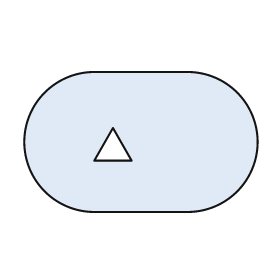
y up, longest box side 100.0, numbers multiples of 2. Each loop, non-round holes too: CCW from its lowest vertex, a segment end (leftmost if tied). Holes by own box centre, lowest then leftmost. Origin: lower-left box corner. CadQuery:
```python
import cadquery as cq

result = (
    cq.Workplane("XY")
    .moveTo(30.0, 0.0)
    .lineTo(70.0, 0.0)
    .threePointArc((100.0, 30.0), (70.0, 60.0))
    .lineTo(30.0, 60.0)
    .threePointArc((0.0, 30.0), (30.0, 0.0))
    .close()
    .moveTo(30.0, 22.0)
    .lineTo(46.0, 22.0)
    .lineTo(38.0, 36.0)
    .close()
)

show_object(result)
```